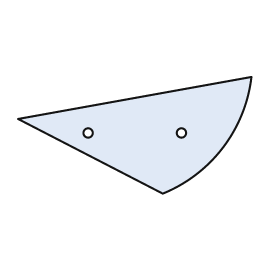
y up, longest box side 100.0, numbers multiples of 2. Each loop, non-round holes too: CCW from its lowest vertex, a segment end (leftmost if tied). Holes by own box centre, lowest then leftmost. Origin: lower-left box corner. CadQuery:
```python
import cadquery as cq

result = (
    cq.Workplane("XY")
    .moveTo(62.0, 0.0)
    .threePointArc((88.0, 20.0), (100.0, 50.0))
    .lineTo(0.0, 32.0)
    .close()
    .moveTo(30.0, 26.0)
    .circle(2.0)
    .moveTo(70.0, 26.0)
    .circle(2.0)
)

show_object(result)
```